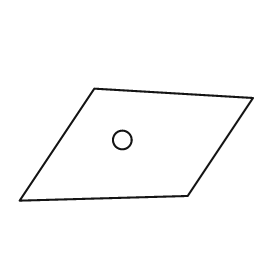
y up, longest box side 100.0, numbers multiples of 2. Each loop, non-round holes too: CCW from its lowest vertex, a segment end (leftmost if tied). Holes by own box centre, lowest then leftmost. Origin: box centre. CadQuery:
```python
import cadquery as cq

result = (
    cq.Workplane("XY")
    .moveTo(-50.0, -24.0)
    .lineTo(22.0, -22.0)
    .lineTo(50.0, 20.0)
    .lineTo(-18.0, 24.0)
    .close()
    .moveTo(-6.0, 2.0)
    .circle(4.0)
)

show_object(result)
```